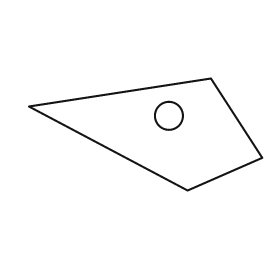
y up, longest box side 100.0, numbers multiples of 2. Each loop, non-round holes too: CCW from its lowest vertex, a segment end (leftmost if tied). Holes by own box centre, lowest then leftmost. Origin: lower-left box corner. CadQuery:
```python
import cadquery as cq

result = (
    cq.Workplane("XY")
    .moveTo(68.0, 0.0)
    .lineTo(100.0, 14.0)
    .lineTo(78.0, 48.0)
    .lineTo(0.0, 36.0)
    .close()
    .moveTo(60.0, 32.0)
    .circle(6.0)
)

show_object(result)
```